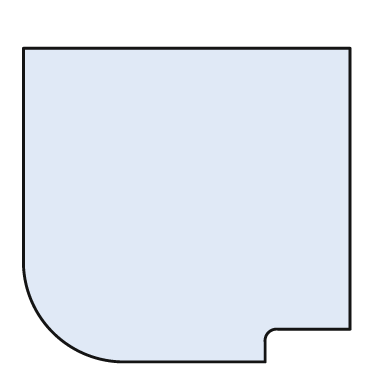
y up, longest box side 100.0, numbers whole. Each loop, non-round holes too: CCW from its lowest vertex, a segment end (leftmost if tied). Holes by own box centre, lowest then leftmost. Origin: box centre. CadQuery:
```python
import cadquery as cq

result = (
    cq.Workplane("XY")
    .moveTo(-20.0, -48.0)
    .lineTo(24.0, -48.0)
    .lineTo(24.0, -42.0)
    .threePointArc((25.0, -39.0), (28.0, -38.0))
    .lineTo(50.0, -38.0)
    .lineTo(50.0, 48.0)
    .lineTo(-50.0, 48.0)
    .lineTo(-50.0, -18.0)
    .threePointArc((-41.0, -39.0), (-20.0, -48.0))
    .close()
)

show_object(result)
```